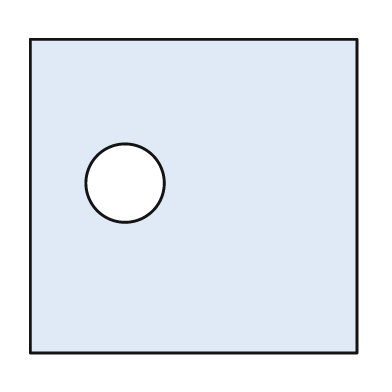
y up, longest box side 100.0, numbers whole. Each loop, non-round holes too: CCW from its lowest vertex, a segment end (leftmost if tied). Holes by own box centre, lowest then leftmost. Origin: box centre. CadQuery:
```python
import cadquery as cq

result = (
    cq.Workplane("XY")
    .moveTo(-50.0, -48.0)
    .lineTo(50.0, -48.0)
    .lineTo(50.0, 48.0)
    .lineTo(-50.0, 48.0)
    .close()
    .moveTo(-21.0, 4.0)
    .circle(12.0)
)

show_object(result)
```